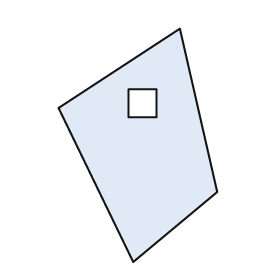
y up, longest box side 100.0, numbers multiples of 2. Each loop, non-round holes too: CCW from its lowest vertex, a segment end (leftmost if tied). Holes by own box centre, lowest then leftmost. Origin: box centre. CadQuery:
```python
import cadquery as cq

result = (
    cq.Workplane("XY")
    .moveTo(-2.0, -50.0)
    .lineTo(34.0, -20.0)
    .lineTo(18.0, 50.0)
    .lineTo(-34.0, 16.0)
    .close()
    .moveTo(-4.0, 12.0)
    .lineTo(8.0, 12.0)
    .lineTo(8.0, 24.0)
    .lineTo(-4.0, 24.0)
    .close()
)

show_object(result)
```